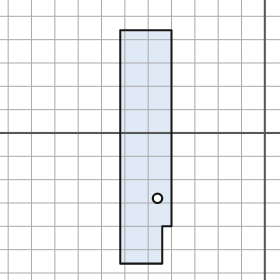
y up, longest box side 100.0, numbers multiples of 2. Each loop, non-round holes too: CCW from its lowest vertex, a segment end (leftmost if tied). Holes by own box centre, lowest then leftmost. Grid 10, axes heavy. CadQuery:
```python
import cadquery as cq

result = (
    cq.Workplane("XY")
    .moveTo(-62.0, -56.0)
    .lineTo(-44.0, -56.0)
    .lineTo(-44.0, -40.0)
    .lineTo(-40.0, -40.0)
    .lineTo(-40.0, 44.0)
    .lineTo(-62.0, 44.0)
    .close()
    .moveTo(-46.0, -28.0)
    .circle(2.0)
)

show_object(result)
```